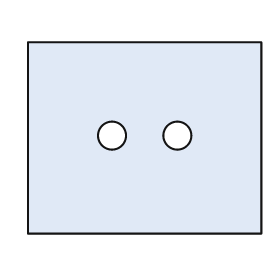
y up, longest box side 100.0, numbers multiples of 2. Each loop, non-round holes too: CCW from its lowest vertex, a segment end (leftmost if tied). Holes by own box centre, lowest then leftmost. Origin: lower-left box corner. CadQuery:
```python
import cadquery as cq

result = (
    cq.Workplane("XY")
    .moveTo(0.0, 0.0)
    .lineTo(100.0, 0.0)
    .lineTo(100.0, 82.0)
    .lineTo(0.0, 82.0)
    .close()
    .moveTo(36.0, 42.0)
    .circle(6.0)
    .moveTo(64.0, 42.0)
    .circle(6.0)
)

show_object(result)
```